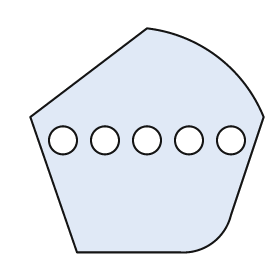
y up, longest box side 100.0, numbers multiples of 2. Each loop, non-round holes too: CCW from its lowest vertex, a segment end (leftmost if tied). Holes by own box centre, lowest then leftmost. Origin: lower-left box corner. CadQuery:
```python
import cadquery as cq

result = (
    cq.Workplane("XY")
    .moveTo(20.0, 0.0)
    .lineTo(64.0, 0.0)
    .threePointArc((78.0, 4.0), (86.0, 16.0))
    .lineTo(100.0, 58.0)
    .threePointArc((80.0, 84.0), (50.0, 96.0))
    .lineTo(0.0, 58.0)
    .close()
    .moveTo(14.0, 48.0)
    .circle(6.0)
    .moveTo(32.0, 48.0)
    .circle(6.0)
    .moveTo(50.0, 48.0)
    .circle(6.0)
    .moveTo(68.0, 48.0)
    .circle(6.0)
    .moveTo(86.0, 48.0)
    .circle(6.0)
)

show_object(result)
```